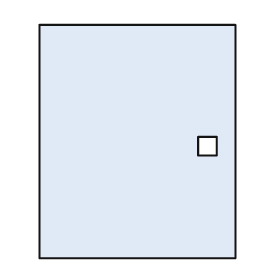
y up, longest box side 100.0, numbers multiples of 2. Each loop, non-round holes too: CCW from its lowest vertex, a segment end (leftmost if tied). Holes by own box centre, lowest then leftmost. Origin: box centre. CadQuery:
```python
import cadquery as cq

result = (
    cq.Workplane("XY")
    .moveTo(-42.0, -50.0)
    .lineTo(42.0, -50.0)
    .lineTo(42.0, 50.0)
    .lineTo(-42.0, 50.0)
    .close()
    .moveTo(26.0, -6.0)
    .lineTo(34.0, -6.0)
    .lineTo(34.0, 2.0)
    .lineTo(26.0, 2.0)
    .close()
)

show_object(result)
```